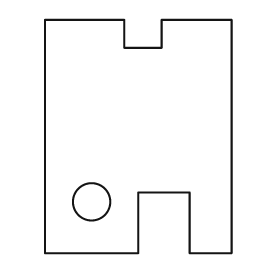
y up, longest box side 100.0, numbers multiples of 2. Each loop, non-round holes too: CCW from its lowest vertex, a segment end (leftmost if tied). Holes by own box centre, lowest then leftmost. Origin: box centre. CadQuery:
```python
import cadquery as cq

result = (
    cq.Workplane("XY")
    .moveTo(-40.0, -50.0)
    .lineTo(0.0, -50.0)
    .lineTo(0.0, -24.0)
    .lineTo(22.0, -24.0)
    .lineTo(22.0, -50.0)
    .lineTo(40.0, -50.0)
    .lineTo(40.0, 50.0)
    .lineTo(10.0, 50.0)
    .lineTo(10.0, 38.0)
    .lineTo(-6.0, 38.0)
    .lineTo(-6.0, 50.0)
    .lineTo(-40.0, 50.0)
    .close()
    .moveTo(-20.0, -28.0)
    .circle(8.0)
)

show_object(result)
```